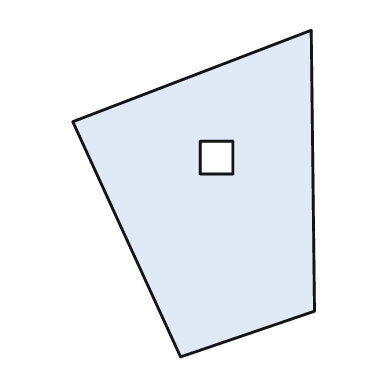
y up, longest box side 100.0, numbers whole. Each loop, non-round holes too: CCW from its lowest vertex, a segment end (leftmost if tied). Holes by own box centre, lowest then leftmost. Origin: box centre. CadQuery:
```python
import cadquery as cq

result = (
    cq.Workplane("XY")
    .moveTo(-4.0, -50.0)
    .lineTo(37.0, -36.0)
    .lineTo(36.0, 50.0)
    .lineTo(-37.0, 22.0)
    .close()
    .moveTo(2.0, 6.0)
    .lineTo(12.0, 6.0)
    .lineTo(12.0, 16.0)
    .lineTo(2.0, 16.0)
    .close()
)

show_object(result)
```